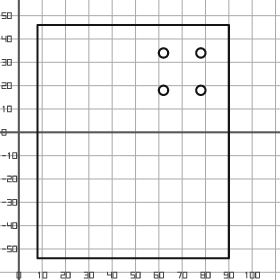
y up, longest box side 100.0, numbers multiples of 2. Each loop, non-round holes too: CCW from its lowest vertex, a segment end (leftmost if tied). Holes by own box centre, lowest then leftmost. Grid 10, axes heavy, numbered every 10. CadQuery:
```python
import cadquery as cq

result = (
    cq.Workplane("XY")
    .moveTo(8.0, -54.0)
    .lineTo(90.0, -54.0)
    .lineTo(90.0, 46.0)
    .lineTo(8.0, 46.0)
    .close()
    .moveTo(62.0, 18.0)
    .circle(2.0)
    .moveTo(78.0, 18.0)
    .circle(2.0)
    .moveTo(62.0, 34.0)
    .circle(2.0)
    .moveTo(78.0, 34.0)
    .circle(2.0)
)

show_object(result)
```